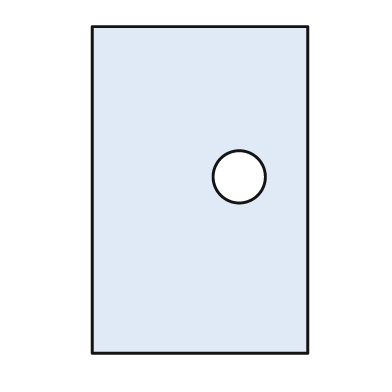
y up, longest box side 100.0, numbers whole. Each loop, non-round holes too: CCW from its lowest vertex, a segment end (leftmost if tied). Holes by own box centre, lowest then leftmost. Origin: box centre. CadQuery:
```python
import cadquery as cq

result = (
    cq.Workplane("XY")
    .moveTo(-33.0, -50.0)
    .lineTo(33.0, -50.0)
    .lineTo(33.0, 50.0)
    .lineTo(-33.0, 50.0)
    .close()
    .moveTo(12.0, 4.0)
    .circle(8.0)
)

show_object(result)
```